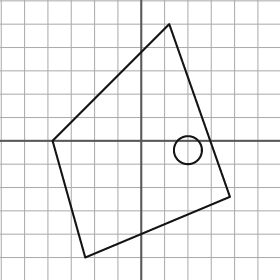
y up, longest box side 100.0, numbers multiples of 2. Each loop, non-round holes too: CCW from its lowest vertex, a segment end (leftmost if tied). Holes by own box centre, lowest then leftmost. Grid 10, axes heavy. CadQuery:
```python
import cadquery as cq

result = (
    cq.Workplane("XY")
    .moveTo(-24.0, -50.0)
    .lineTo(38.0, -24.0)
    .lineTo(12.0, 50.0)
    .lineTo(-38.0, 0.0)
    .close()
    .moveTo(20.0, -4.0)
    .circle(6.0)
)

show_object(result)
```